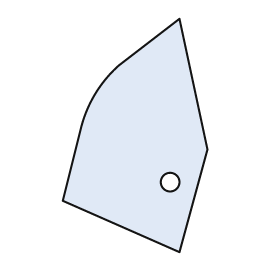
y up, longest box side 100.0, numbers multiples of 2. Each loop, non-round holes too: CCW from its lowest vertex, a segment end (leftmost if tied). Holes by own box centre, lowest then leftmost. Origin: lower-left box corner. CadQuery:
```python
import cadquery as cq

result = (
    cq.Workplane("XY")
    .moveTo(50.0, 0.0)
    .lineTo(62.0, 44.0)
    .lineTo(50.0, 100.0)
    .lineTo(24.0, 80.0)
    .threePointArc((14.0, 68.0), (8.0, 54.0))
    .lineTo(0.0, 22.0)
    .close()
    .moveTo(46.0, 30.0)
    .circle(4.0)
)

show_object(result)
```